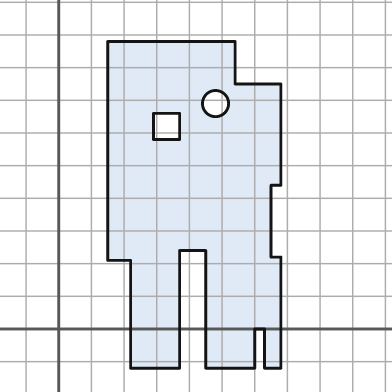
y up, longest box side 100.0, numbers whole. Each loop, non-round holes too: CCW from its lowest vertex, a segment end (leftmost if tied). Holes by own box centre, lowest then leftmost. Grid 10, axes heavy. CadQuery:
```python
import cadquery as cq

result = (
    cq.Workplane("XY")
    .moveTo(22.0, -12.0)
    .lineTo(37.0, -12.0)
    .lineTo(37.0, 24.0)
    .lineTo(45.0, 24.0)
    .lineTo(45.0, -12.0)
    .lineTo(60.0, -12.0)
    .lineTo(60.0, 0.0)
    .lineTo(63.0, 0.0)
    .lineTo(63.0, -12.0)
    .lineTo(68.0, -12.0)
    .lineTo(68.0, 22.0)
    .lineTo(65.0, 22.0)
    .lineTo(65.0, 44.0)
    .lineTo(68.0, 44.0)
    .lineTo(68.0, 75.0)
    .lineTo(54.0, 75.0)
    .lineTo(54.0, 88.0)
    .lineTo(15.0, 88.0)
    .lineTo(15.0, 21.0)
    .lineTo(22.0, 21.0)
    .close()
    .moveTo(29.0, 58.0)
    .lineTo(37.0, 58.0)
    .lineTo(37.0, 66.0)
    .lineTo(29.0, 66.0)
    .close()
    .moveTo(48.0, 69.0)
    .circle(4.0)
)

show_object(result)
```